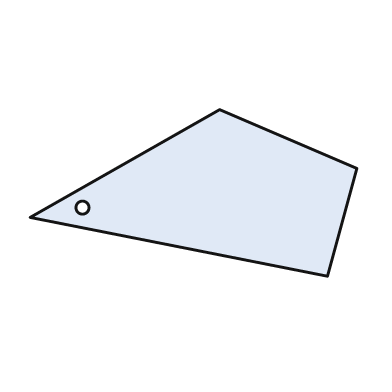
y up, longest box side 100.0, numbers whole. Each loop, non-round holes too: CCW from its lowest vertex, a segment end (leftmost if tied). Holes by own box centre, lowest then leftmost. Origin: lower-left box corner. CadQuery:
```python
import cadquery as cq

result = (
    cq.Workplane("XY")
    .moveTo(91.0, 0.0)
    .lineTo(100.0, 33.0)
    .lineTo(58.0, 51.0)
    .lineTo(0.0, 18.0)
    .close()
    .moveTo(16.0, 21.0)
    .circle(2.0)
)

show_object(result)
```